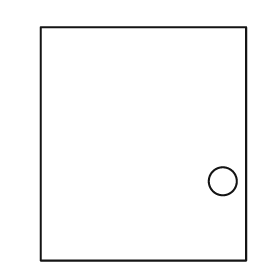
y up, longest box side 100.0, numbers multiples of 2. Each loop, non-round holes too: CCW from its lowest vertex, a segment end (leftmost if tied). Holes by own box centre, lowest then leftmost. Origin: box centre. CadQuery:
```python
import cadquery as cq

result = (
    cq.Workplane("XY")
    .moveTo(-44.0, -50.0)
    .lineTo(44.0, -50.0)
    .lineTo(44.0, 50.0)
    .lineTo(-44.0, 50.0)
    .close()
    .moveTo(34.0, -16.0)
    .circle(6.0)
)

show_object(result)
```